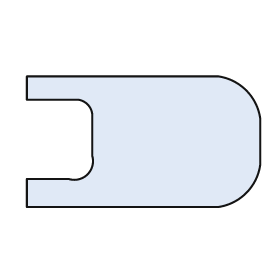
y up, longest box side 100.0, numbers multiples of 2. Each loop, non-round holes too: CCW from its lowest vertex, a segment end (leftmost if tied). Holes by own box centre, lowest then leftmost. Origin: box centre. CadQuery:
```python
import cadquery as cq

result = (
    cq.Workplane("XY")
    .moveTo(-50.0, -28.0)
    .lineTo(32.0, -28.0)
    .threePointArc((44.0, -22.0), (50.0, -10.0))
    .lineTo(50.0, 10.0)
    .threePointArc((44.0, 22.0), (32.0, 28.0))
    .lineTo(-50.0, 28.0)
    .lineTo(-50.0, 18.0)
    .lineTo(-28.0, 18.0)
    .threePointArc((-24.0, 16.0), (-22.0, 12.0))
    .lineTo(-22.0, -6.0)
    .threePointArc((-24.0, -14.0), (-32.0, -16.0))
    .lineTo(-50.0, -16.0)
    .close()
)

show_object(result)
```